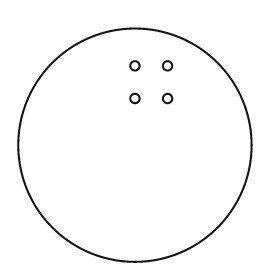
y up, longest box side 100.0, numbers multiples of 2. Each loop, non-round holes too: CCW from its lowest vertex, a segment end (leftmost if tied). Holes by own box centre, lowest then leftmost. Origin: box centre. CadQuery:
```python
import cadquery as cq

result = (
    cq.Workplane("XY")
    .moveTo(0.0, 0.0)
    .circle(50.0)
    .moveTo(0.0, 20.0)
    .circle(2.0)
    .moveTo(14.0, 20.0)
    .circle(2.0)
    .moveTo(0.0, 34.0)
    .circle(2.0)
    .moveTo(14.0, 34.0)
    .circle(2.0)
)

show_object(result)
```